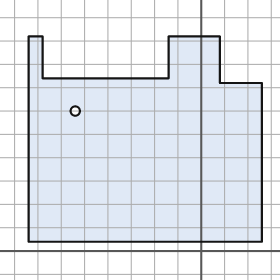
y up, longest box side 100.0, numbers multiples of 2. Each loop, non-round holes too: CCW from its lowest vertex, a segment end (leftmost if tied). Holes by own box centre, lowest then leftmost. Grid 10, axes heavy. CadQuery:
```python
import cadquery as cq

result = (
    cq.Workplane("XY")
    .moveTo(-74.0, 4.0)
    .lineTo(26.0, 4.0)
    .lineTo(26.0, 72.0)
    .lineTo(8.0, 72.0)
    .lineTo(8.0, 92.0)
    .lineTo(-14.0, 92.0)
    .lineTo(-14.0, 74.0)
    .lineTo(-68.0, 74.0)
    .lineTo(-68.0, 92.0)
    .lineTo(-74.0, 92.0)
    .close()
    .moveTo(-54.0, 60.0)
    .circle(2.0)
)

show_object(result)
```